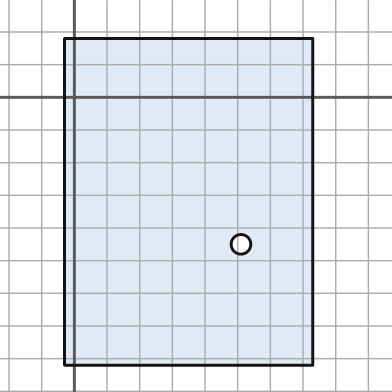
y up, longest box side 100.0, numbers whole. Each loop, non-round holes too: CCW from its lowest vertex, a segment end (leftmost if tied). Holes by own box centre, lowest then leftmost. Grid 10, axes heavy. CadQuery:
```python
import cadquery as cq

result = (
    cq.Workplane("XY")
    .moveTo(-3.0, -82.0)
    .lineTo(73.0, -82.0)
    .lineTo(73.0, 18.0)
    .lineTo(-3.0, 18.0)
    .close()
    .moveTo(51.0, -45.0)
    .circle(3.0)
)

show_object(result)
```